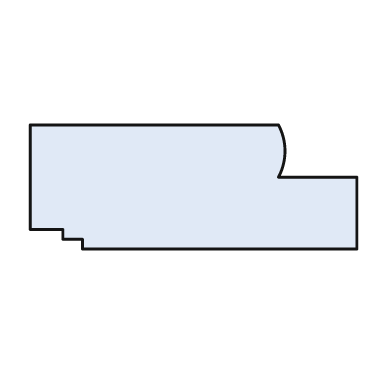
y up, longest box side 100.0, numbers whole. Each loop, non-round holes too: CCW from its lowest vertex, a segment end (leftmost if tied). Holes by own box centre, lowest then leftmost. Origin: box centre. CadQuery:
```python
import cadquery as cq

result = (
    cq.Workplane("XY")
    .moveTo(-34.0, -19.0)
    .lineTo(50.0, -19.0)
    .lineTo(50.0, 3.0)
    .lineTo(26.0, 3.0)
    .threePointArc((28.0, 11.0), (26.0, 19.0))
    .lineTo(-50.0, 19.0)
    .lineTo(-50.0, -13.0)
    .lineTo(-40.0, -13.0)
    .lineTo(-40.0, -16.0)
    .lineTo(-34.0, -16.0)
    .close()
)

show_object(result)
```